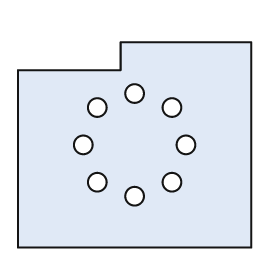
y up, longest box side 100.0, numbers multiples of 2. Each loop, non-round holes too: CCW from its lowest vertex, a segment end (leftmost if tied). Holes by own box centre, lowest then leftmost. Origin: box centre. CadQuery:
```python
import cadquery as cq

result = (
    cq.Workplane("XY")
    .moveTo(-50.0, -44.0)
    .lineTo(50.0, -44.0)
    .lineTo(50.0, 44.0)
    .lineTo(-6.0, 44.0)
    .lineTo(-6.0, 32.0)
    .lineTo(-50.0, 32.0)
    .close()
    .moveTo(0.0, -22.0)
    .circle(4.0)
    .moveTo(-16.0, -16.0)
    .circle(4.0)
    .moveTo(16.0, -16.0)
    .circle(4.0)
    .moveTo(-22.0, 0.0)
    .circle(4.0)
    .moveTo(22.0, 0.0)
    .circle(4.0)
    .moveTo(-16.0, 16.0)
    .circle(4.0)
    .moveTo(16.0, 16.0)
    .circle(4.0)
    .moveTo(0.0, 22.0)
    .circle(4.0)
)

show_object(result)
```